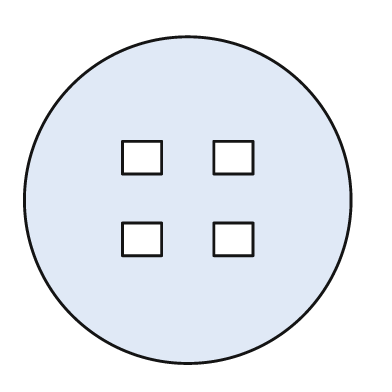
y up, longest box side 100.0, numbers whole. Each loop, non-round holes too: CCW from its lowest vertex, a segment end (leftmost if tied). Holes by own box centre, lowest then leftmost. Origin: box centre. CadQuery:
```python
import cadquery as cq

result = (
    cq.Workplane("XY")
    .moveTo(0.0, 0.0)
    .circle(50.0)
    .moveTo(-20.0, -17.0)
    .lineTo(-8.0, -17.0)
    .lineTo(-8.0, -7.0)
    .lineTo(-20.0, -7.0)
    .close()
    .moveTo(8.0, -17.0)
    .lineTo(20.0, -17.0)
    .lineTo(20.0, -7.0)
    .lineTo(8.0, -7.0)
    .close()
    .moveTo(-20.0, 8.0)
    .lineTo(-8.0, 8.0)
    .lineTo(-8.0, 18.0)
    .lineTo(-20.0, 18.0)
    .close()
    .moveTo(8.0, 8.0)
    .lineTo(20.0, 8.0)
    .lineTo(20.0, 18.0)
    .lineTo(8.0, 18.0)
    .close()
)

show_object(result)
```